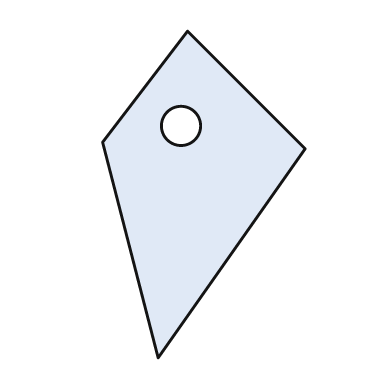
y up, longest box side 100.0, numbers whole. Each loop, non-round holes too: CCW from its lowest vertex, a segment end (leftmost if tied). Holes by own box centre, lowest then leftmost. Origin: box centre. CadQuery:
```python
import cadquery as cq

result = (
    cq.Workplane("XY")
    .moveTo(-14.0, -50.0)
    .lineTo(31.0, 14.0)
    .lineTo(-5.0, 50.0)
    .lineTo(-31.0, 16.0)
    .close()
    .moveTo(-7.0, 21.0)
    .circle(6.0)
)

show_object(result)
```